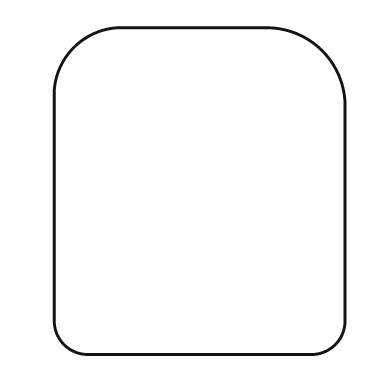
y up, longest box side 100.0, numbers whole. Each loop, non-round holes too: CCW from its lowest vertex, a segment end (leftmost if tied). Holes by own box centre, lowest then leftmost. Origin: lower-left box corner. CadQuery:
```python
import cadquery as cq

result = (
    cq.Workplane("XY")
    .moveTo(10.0, 0.0)
    .lineTo(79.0, 0.0)
    .threePointArc((86.0, 3.0), (89.0, 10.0))
    .lineTo(89.0, 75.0)
    .threePointArc((82.0, 93.0), (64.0, 100.0))
    .lineTo(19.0, 100.0)
    .threePointArc((6.0, 94.0), (0.0, 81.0))
    .lineTo(0.0, 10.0)
    .threePointArc((3.0, 3.0), (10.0, 0.0))
    .close()
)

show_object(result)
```